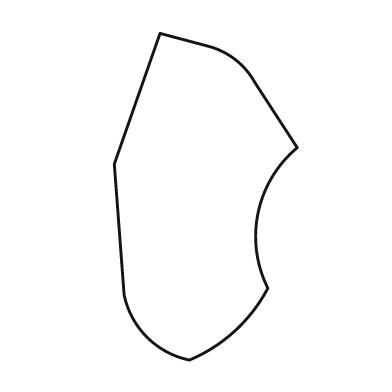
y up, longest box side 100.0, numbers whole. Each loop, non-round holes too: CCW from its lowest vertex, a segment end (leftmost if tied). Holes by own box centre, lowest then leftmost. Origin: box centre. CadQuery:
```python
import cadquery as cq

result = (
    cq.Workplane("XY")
    .moveTo(-5.0, -50.0)
    .threePointArc((9.0, -41.0), (19.0, -28.0))
    .threePointArc((16.0, -5.0), (28.0, 15.0))
    .lineTo(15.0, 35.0)
    .threePointArc((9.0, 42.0), (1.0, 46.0))
    .lineTo(-14.0, 50.0)
    .lineTo(-28.0, 10.0)
    .lineTo(-25.0, -30.0)
    .threePointArc((-18.0, -43.0), (-5.0, -50.0))
    .close()
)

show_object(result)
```